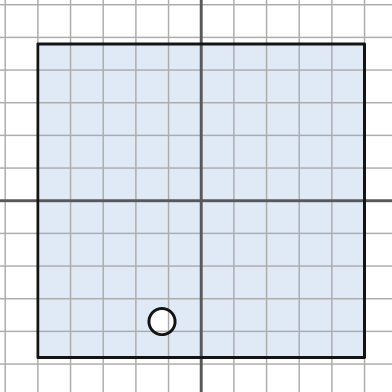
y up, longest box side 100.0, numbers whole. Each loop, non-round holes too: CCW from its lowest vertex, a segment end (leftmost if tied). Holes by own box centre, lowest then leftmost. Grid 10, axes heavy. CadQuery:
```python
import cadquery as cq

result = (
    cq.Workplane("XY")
    .moveTo(-50.0, -48.0)
    .lineTo(50.0, -48.0)
    .lineTo(50.0, 48.0)
    .lineTo(-50.0, 48.0)
    .close()
    .moveTo(-12.0, -37.0)
    .circle(4.0)
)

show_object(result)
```